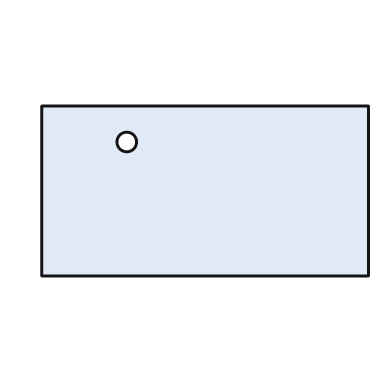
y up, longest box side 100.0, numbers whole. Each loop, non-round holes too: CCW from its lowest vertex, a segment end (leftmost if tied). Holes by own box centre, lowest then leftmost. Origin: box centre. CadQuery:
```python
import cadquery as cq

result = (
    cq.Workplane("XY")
    .moveTo(-50.0, -26.0)
    .lineTo(50.0, -26.0)
    .lineTo(50.0, 26.0)
    .lineTo(-50.0, 26.0)
    .close()
    .moveTo(-24.0, 15.0)
    .circle(3.0)
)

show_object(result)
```